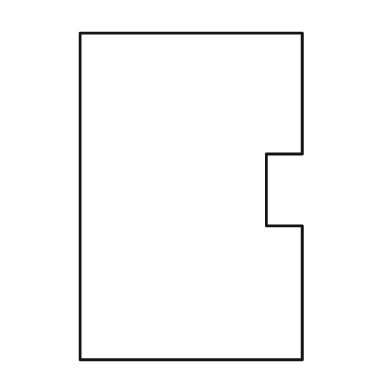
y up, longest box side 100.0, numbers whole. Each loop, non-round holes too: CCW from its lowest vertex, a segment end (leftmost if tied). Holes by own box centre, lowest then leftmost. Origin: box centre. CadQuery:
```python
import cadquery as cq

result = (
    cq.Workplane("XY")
    .moveTo(-34.0, -50.0)
    .lineTo(34.0, -50.0)
    .lineTo(34.0, -9.0)
    .lineTo(23.0, -9.0)
    .lineTo(23.0, 13.0)
    .lineTo(34.0, 13.0)
    .lineTo(34.0, 50.0)
    .lineTo(-34.0, 50.0)
    .close()
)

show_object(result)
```